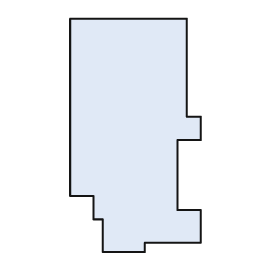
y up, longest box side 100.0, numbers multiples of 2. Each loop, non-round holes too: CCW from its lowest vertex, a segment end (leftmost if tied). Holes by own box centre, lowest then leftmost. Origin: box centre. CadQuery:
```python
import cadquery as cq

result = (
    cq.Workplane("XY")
    .moveTo(-14.0, -50.0)
    .lineTo(4.0, -50.0)
    .lineTo(4.0, -46.0)
    .lineTo(28.0, -46.0)
    .lineTo(28.0, -32.0)
    .lineTo(18.0, -32.0)
    .lineTo(18.0, -2.0)
    .lineTo(28.0, -2.0)
    .lineTo(28.0, 8.0)
    .lineTo(22.0, 8.0)
    .lineTo(22.0, 50.0)
    .lineTo(-28.0, 50.0)
    .lineTo(-28.0, -26.0)
    .lineTo(-18.0, -26.0)
    .lineTo(-18.0, -36.0)
    .lineTo(-14.0, -36.0)
    .close()
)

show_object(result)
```